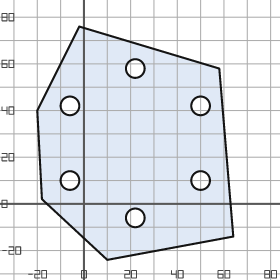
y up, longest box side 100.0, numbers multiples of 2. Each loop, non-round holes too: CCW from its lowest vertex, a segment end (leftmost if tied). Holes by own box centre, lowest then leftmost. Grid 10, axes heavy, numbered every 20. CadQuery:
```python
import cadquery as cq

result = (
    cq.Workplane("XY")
    .moveTo(10.0, -24.0)
    .lineTo(64.0, -14.0)
    .lineTo(58.0, 58.0)
    .lineTo(-2.0, 76.0)
    .lineTo(-20.0, 40.0)
    .lineTo(-18.0, 2.0)
    .close()
    .moveTo(22.0, -6.0)
    .circle(4.0)
    .moveTo(-6.0, 10.0)
    .circle(4.0)
    .moveTo(50.0, 10.0)
    .circle(4.0)
    .moveTo(-6.0, 42.0)
    .circle(4.0)
    .moveTo(50.0, 42.0)
    .circle(4.0)
    .moveTo(22.0, 58.0)
    .circle(4.0)
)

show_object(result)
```